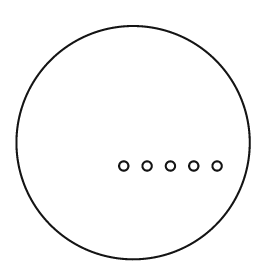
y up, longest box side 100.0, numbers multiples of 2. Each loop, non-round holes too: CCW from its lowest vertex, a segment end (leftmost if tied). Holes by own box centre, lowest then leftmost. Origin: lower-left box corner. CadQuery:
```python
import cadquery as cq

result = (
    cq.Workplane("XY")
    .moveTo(50.0, 50.0)
    .circle(50.0)
    .moveTo(46.0, 40.0)
    .circle(2.0)
    .moveTo(56.0, 40.0)
    .circle(2.0)
    .moveTo(66.0, 40.0)
    .circle(2.0)
    .moveTo(76.0, 40.0)
    .circle(2.0)
    .moveTo(86.0, 40.0)
    .circle(2.0)
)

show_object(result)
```